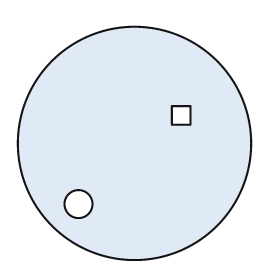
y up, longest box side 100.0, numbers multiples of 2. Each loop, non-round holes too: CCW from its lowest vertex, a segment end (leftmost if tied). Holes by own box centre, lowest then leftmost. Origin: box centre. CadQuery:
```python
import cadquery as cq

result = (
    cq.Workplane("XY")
    .moveTo(0.0, 0.0)
    .circle(50.0)
    .moveTo(-24.0, -26.0)
    .circle(6.0)
    .moveTo(16.0, 8.0)
    .lineTo(24.0, 8.0)
    .lineTo(24.0, 16.0)
    .lineTo(16.0, 16.0)
    .close()
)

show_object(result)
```